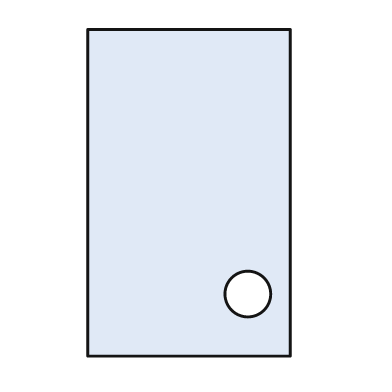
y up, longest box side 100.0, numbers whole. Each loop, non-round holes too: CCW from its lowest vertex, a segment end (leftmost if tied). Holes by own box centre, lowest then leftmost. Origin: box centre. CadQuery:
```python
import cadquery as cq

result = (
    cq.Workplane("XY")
    .moveTo(-31.0, -50.0)
    .lineTo(31.0, -50.0)
    .lineTo(31.0, 50.0)
    .lineTo(-31.0, 50.0)
    .close()
    .moveTo(18.0, -31.0)
    .circle(7.0)
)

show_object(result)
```